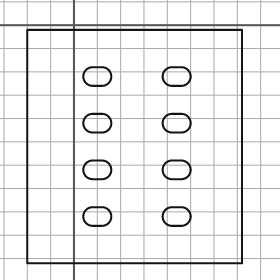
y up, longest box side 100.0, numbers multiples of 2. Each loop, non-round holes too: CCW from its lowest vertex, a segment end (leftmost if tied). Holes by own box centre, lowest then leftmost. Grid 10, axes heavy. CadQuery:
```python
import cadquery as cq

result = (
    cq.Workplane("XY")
    .moveTo(-20.0, -102.0)
    .lineTo(72.0, -102.0)
    .lineTo(72.0, -2.0)
    .lineTo(-20.0, -2.0)
    .close()
    .moveTo(8.0, -86.0)
    .lineTo(12.0, -86.0)
    .threePointArc((16.0, -82.0), (12.0, -78.0))
    .lineTo(8.0, -78.0)
    .threePointArc((4.0, -82.0), (8.0, -86.0))
    .close()
    .moveTo(42.0, -86.0)
    .lineTo(46.0, -86.0)
    .threePointArc((50.0, -82.0), (46.0, -78.0))
    .lineTo(42.0, -78.0)
    .threePointArc((38.0, -82.0), (42.0, -86.0))
    .close()
    .moveTo(8.0, -66.0)
    .lineTo(12.0, -66.0)
    .threePointArc((16.0, -62.0), (12.0, -58.0))
    .lineTo(8.0, -58.0)
    .threePointArc((4.0, -62.0), (8.0, -66.0))
    .close()
    .moveTo(42.0, -66.0)
    .lineTo(46.0, -66.0)
    .threePointArc((50.0, -62.0), (46.0, -58.0))
    .lineTo(42.0, -58.0)
    .threePointArc((38.0, -62.0), (42.0, -66.0))
    .close()
    .moveTo(8.0, -46.0)
    .lineTo(12.0, -46.0)
    .threePointArc((16.0, -42.0), (12.0, -38.0))
    .lineTo(8.0, -38.0)
    .threePointArc((4.0, -42.0), (8.0, -46.0))
    .close()
    .moveTo(42.0, -46.0)
    .lineTo(46.0, -46.0)
    .threePointArc((50.0, -42.0), (46.0, -38.0))
    .lineTo(42.0, -38.0)
    .threePointArc((38.0, -42.0), (42.0, -46.0))
    .close()
    .moveTo(8.0, -26.0)
    .lineTo(12.0, -26.0)
    .threePointArc((16.0, -22.0), (12.0, -18.0))
    .lineTo(8.0, -18.0)
    .threePointArc((4.0, -22.0), (8.0, -26.0))
    .close()
    .moveTo(42.0, -26.0)
    .lineTo(46.0, -26.0)
    .threePointArc((50.0, -22.0), (46.0, -18.0))
    .lineTo(42.0, -18.0)
    .threePointArc((38.0, -22.0), (42.0, -26.0))
    .close()
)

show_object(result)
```